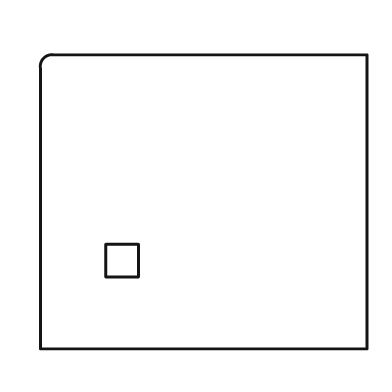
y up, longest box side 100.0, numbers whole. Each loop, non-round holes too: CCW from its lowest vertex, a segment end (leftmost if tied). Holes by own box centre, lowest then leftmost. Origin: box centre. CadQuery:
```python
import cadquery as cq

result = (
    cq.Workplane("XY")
    .moveTo(-50.0, -45.0)
    .lineTo(50.0, -45.0)
    .lineTo(50.0, 45.0)
    .lineTo(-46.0, 45.0)
    .threePointArc((-49.0, 44.0), (-50.0, 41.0))
    .close()
    .moveTo(-30.0, -23.0)
    .lineTo(-20.0, -23.0)
    .lineTo(-20.0, -13.0)
    .lineTo(-30.0, -13.0)
    .close()
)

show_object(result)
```